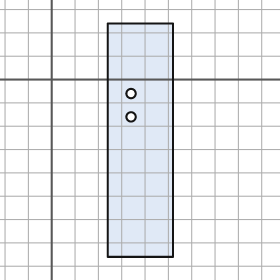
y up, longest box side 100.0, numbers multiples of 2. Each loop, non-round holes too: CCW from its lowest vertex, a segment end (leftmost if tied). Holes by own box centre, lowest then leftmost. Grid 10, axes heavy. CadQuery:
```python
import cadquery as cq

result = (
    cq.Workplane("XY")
    .moveTo(24.0, -76.0)
    .lineTo(52.0, -76.0)
    .lineTo(52.0, 24.0)
    .lineTo(24.0, 24.0)
    .close()
    .moveTo(34.0, -16.0)
    .circle(2.0)
    .moveTo(34.0, -6.0)
    .circle(2.0)
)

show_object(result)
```